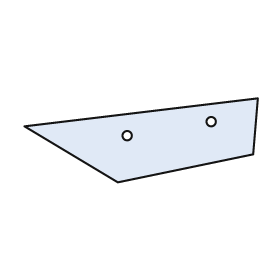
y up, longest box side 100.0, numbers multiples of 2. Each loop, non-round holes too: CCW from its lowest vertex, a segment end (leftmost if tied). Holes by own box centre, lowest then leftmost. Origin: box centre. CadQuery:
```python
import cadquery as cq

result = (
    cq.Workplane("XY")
    .moveTo(-10.0, -18.0)
    .lineTo(48.0, -6.0)
    .lineTo(50.0, 18.0)
    .lineTo(-50.0, 6.0)
    .close()
    .moveTo(-6.0, 2.0)
    .circle(2.0)
    .moveTo(30.0, 8.0)
    .circle(2.0)
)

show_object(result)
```